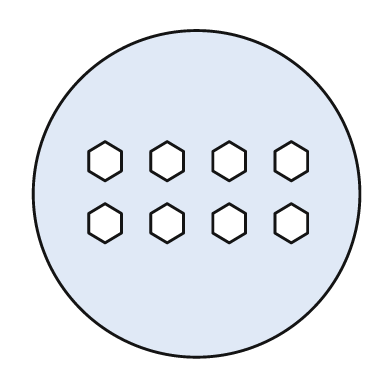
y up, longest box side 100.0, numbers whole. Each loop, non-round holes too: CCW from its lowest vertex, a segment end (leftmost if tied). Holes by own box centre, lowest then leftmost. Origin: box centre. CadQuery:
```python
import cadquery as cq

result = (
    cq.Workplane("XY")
    .moveTo(0.0, 0.0)
    .circle(50.0)
    .moveTo(-28.0, -15.0)
    .lineTo(-23.0, -12.0)
    .lineTo(-23.0, -6.0)
    .lineTo(-28.0, -3.0)
    .lineTo(-33.0, -6.0)
    .lineTo(-33.0, -12.0)
    .close()
    .moveTo(-9.0, -15.0)
    .lineTo(-4.0, -12.0)
    .lineTo(-4.0, -6.0)
    .lineTo(-9.0, -3.0)
    .lineTo(-14.0, -6.0)
    .lineTo(-14.0, -12.0)
    .close()
    .moveTo(10.0, -15.0)
    .lineTo(15.0, -12.0)
    .lineTo(15.0, -6.0)
    .lineTo(10.0, -3.0)
    .lineTo(5.0, -6.0)
    .lineTo(5.0, -12.0)
    .close()
    .moveTo(29.0, -15.0)
    .lineTo(34.0, -12.0)
    .lineTo(34.0, -6.0)
    .lineTo(29.0, -3.0)
    .lineTo(24.0, -6.0)
    .lineTo(24.0, -12.0)
    .close()
    .moveTo(-28.0, 4.0)
    .lineTo(-23.0, 7.0)
    .lineTo(-23.0, 13.0)
    .lineTo(-28.0, 16.0)
    .lineTo(-33.0, 13.0)
    .lineTo(-33.0, 7.0)
    .close()
    .moveTo(-9.0, 4.0)
    .lineTo(-4.0, 7.0)
    .lineTo(-4.0, 13.0)
    .lineTo(-9.0, 16.0)
    .lineTo(-14.0, 13.0)
    .lineTo(-14.0, 7.0)
    .close()
    .moveTo(10.0, 4.0)
    .lineTo(15.0, 7.0)
    .lineTo(15.0, 13.0)
    .lineTo(10.0, 16.0)
    .lineTo(5.0, 13.0)
    .lineTo(5.0, 7.0)
    .close()
    .moveTo(29.0, 4.0)
    .lineTo(34.0, 7.0)
    .lineTo(34.0, 13.0)
    .lineTo(29.0, 16.0)
    .lineTo(24.0, 13.0)
    .lineTo(24.0, 7.0)
    .close()
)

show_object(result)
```